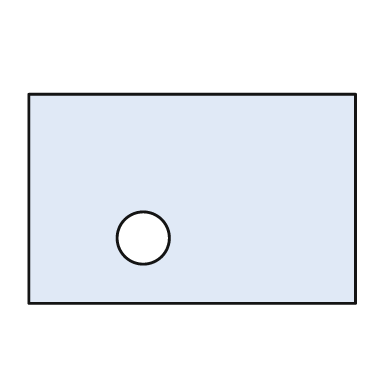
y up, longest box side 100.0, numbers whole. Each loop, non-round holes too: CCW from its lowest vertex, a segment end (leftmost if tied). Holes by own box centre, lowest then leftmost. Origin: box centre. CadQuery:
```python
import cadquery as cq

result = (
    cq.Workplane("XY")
    .moveTo(-50.0, -32.0)
    .lineTo(50.0, -32.0)
    .lineTo(50.0, 32.0)
    .lineTo(-50.0, 32.0)
    .close()
    .moveTo(-15.0, -12.0)
    .circle(8.0)
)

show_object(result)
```